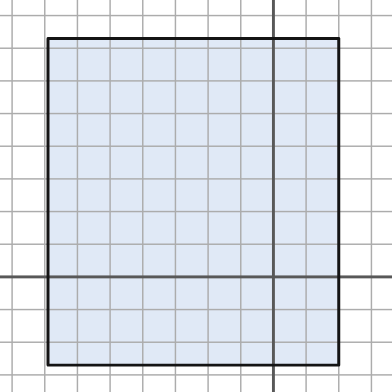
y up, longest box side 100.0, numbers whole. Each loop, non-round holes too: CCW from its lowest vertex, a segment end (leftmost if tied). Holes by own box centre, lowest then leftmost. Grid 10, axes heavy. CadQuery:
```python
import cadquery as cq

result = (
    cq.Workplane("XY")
    .moveTo(-69.0, -27.0)
    .lineTo(20.0, -27.0)
    .lineTo(20.0, 73.0)
    .lineTo(-69.0, 73.0)
    .close()
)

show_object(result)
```